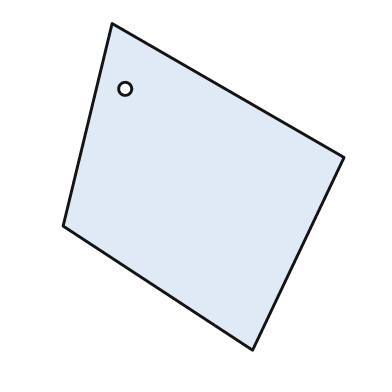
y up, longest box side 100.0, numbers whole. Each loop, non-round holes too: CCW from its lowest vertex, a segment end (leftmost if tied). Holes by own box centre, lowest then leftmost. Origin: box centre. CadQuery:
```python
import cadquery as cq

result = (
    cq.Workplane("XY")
    .moveTo(15.0, -50.0)
    .lineTo(43.0, 9.0)
    .lineTo(-28.0, 50.0)
    .lineTo(-43.0, -12.0)
    .close()
    .moveTo(-24.0, 30.0)
    .circle(2.0)
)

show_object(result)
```